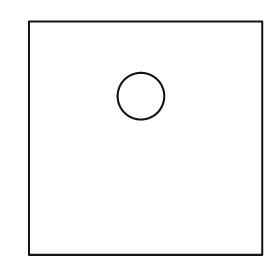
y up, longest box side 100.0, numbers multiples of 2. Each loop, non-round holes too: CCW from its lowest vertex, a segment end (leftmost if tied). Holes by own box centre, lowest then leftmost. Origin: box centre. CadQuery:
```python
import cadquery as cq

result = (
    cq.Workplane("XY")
    .moveTo(-50.0, -50.0)
    .lineTo(50.0, -50.0)
    .lineTo(50.0, 50.0)
    .lineTo(-50.0, 50.0)
    .close()
    .moveTo(-2.0, 18.0)
    .circle(10.0)
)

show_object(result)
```